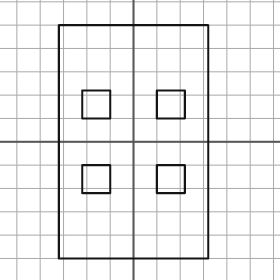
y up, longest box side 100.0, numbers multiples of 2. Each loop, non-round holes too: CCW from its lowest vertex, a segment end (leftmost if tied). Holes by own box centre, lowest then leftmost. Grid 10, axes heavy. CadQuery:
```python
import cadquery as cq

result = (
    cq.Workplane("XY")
    .moveTo(-32.0, -50.0)
    .lineTo(32.0, -50.0)
    .lineTo(32.0, 50.0)
    .lineTo(-32.0, 50.0)
    .close()
    .moveTo(-22.0, -22.0)
    .lineTo(-10.0, -22.0)
    .lineTo(-10.0, -10.0)
    .lineTo(-22.0, -10.0)
    .close()
    .moveTo(10.0, -22.0)
    .lineTo(22.0, -22.0)
    .lineTo(22.0, -10.0)
    .lineTo(10.0, -10.0)
    .close()
    .moveTo(-22.0, 10.0)
    .lineTo(-10.0, 10.0)
    .lineTo(-10.0, 22.0)
    .lineTo(-22.0, 22.0)
    .close()
    .moveTo(10.0, 10.0)
    .lineTo(22.0, 10.0)
    .lineTo(22.0, 22.0)
    .lineTo(10.0, 22.0)
    .close()
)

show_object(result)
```